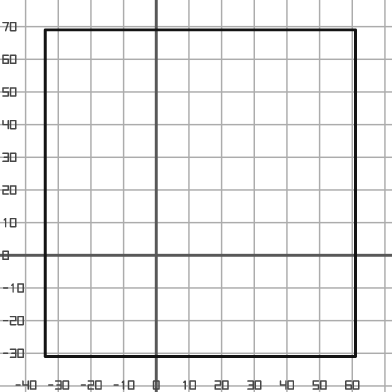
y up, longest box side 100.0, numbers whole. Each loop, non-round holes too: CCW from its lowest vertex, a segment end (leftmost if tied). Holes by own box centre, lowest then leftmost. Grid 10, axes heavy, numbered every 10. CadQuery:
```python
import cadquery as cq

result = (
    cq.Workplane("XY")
    .moveTo(-34.0, -31.0)
    .lineTo(61.0, -31.0)
    .lineTo(61.0, 69.0)
    .lineTo(-34.0, 69.0)
    .close()
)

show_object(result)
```